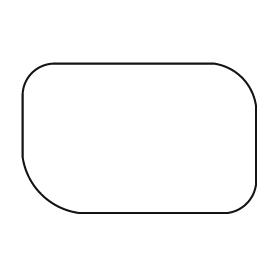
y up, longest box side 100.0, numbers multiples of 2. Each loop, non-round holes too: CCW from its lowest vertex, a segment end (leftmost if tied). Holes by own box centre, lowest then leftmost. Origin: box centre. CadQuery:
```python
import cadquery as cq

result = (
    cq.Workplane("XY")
    .moveTo(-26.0, -32.0)
    .lineTo(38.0, -32.0)
    .threePointArc((46.0, -28.0), (50.0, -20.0))
    .lineTo(50.0, 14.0)
    .threePointArc((44.0, 26.0), (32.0, 32.0))
    .lineTo(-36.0, 32.0)
    .threePointArc((-46.0, 28.0), (-50.0, 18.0))
    .lineTo(-50.0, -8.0)
    .threePointArc((-42.0, -24.0), (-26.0, -32.0))
    .close()
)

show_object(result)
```